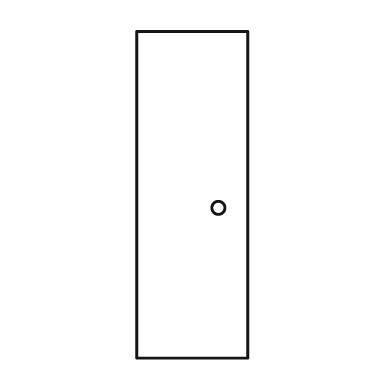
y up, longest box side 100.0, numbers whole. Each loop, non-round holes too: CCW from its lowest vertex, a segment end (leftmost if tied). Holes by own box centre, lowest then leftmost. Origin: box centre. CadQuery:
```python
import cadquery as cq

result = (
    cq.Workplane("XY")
    .moveTo(-17.0, -50.0)
    .lineTo(17.0, -50.0)
    .lineTo(17.0, 50.0)
    .lineTo(-17.0, 50.0)
    .close()
    .moveTo(8.0, -4.0)
    .circle(2.0)
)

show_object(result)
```